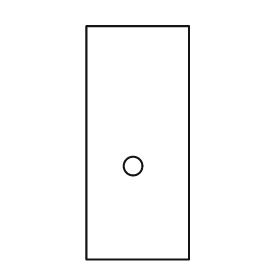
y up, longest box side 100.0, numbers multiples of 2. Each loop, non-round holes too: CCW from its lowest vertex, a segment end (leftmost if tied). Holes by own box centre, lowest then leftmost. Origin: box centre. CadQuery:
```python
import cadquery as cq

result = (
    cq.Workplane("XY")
    .moveTo(-22.0, -50.0)
    .lineTo(22.0, -50.0)
    .lineTo(22.0, 50.0)
    .lineTo(-22.0, 50.0)
    .close()
    .moveTo(-2.0, -10.0)
    .circle(4.0)
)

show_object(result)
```